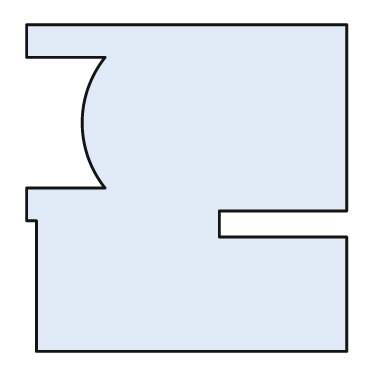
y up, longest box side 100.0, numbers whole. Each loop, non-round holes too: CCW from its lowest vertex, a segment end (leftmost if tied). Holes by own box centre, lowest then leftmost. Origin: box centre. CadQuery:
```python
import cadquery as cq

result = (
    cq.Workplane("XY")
    .moveTo(-46.0, -50.0)
    .lineTo(49.0, -50.0)
    .lineTo(49.0, -15.0)
    .lineTo(10.0, -15.0)
    .lineTo(10.0, -7.0)
    .lineTo(49.0, -7.0)
    .lineTo(49.0, 50.0)
    .lineTo(-49.0, 50.0)
    .lineTo(-49.0, 40.0)
    .lineTo(-25.0, 40.0)
    .threePointArc((-32.0, 20.0), (-25.0, 0.0))
    .lineTo(-49.0, 0.0)
    .lineTo(-49.0, -10.0)
    .lineTo(-46.0, -10.0)
    .close()
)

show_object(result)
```